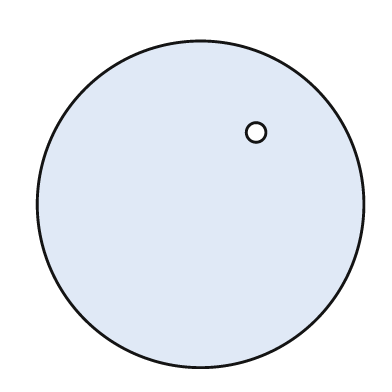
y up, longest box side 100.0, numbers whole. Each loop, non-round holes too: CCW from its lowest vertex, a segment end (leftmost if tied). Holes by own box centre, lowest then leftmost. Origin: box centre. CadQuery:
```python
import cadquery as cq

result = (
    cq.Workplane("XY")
    .moveTo(0.0, 0.0)
    .circle(50.0)
    .moveTo(17.0, 22.0)
    .circle(3.0)
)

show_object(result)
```